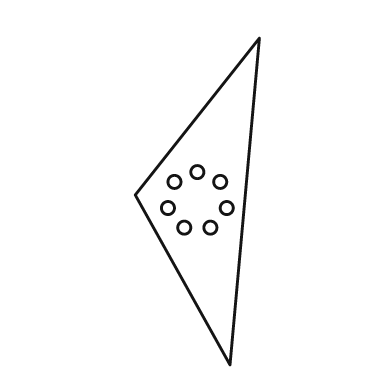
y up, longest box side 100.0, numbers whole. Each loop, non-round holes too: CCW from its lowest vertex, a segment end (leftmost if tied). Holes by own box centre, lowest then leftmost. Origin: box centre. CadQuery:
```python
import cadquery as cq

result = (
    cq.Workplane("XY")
    .moveTo(10.0, -50.0)
    .lineTo(19.0, 50.0)
    .lineTo(-19.0, 2.0)
    .close()
    .moveTo(-4.0, -8.0)
    .circle(2.0)
    .moveTo(4.0, -8.0)
    .circle(2.0)
    .moveTo(-9.0, -2.0)
    .circle(2.0)
    .moveTo(9.0, -2.0)
    .circle(2.0)
    .moveTo(-7.0, 6.0)
    .circle(2.0)
    .moveTo(7.0, 6.0)
    .circle(2.0)
    .moveTo(0.0, 9.0)
    .circle(2.0)
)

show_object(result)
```